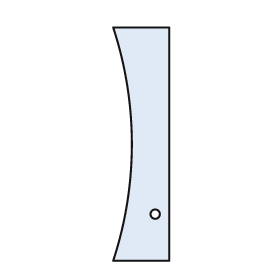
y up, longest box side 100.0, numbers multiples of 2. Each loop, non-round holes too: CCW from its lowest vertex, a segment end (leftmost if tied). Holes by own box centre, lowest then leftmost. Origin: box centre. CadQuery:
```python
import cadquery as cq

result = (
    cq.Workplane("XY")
    .moveTo(-12.0, -50.0)
    .lineTo(12.0, -50.0)
    .lineTo(12.0, 50.0)
    .lineTo(-12.0, 50.0)
    .threePointArc((-4.0, 0.0), (-12.0, -50.0))
    .close()
    .moveTo(6.0, -30.0)
    .circle(2.0)
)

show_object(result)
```